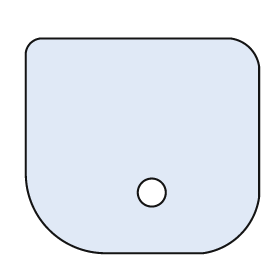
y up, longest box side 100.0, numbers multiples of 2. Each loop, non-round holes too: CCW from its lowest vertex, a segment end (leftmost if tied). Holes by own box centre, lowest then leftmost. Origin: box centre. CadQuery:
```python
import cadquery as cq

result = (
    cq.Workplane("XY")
    .moveTo(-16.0, -46.0)
    .lineTo(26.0, -46.0)
    .threePointArc((42.0, -38.0), (50.0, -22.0))
    .lineTo(50.0, 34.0)
    .threePointArc((46.0, 42.0), (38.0, 46.0))
    .lineTo(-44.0, 46.0)
    .threePointArc((-48.0, 44.0), (-50.0, 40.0))
    .lineTo(-50.0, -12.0)
    .threePointArc((-40.0, -36.0), (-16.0, -46.0))
    .close()
    .moveTo(4.0, -20.0)
    .circle(6.0)
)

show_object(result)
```